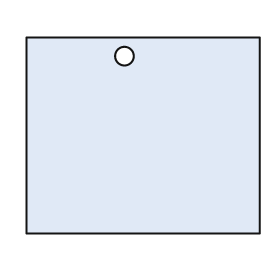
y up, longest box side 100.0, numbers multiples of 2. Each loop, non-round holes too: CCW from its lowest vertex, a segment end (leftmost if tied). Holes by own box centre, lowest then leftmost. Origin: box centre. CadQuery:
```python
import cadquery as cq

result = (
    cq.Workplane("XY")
    .moveTo(-50.0, -42.0)
    .lineTo(50.0, -42.0)
    .lineTo(50.0, 42.0)
    .lineTo(-50.0, 42.0)
    .close()
    .moveTo(-8.0, 34.0)
    .circle(4.0)
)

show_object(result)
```